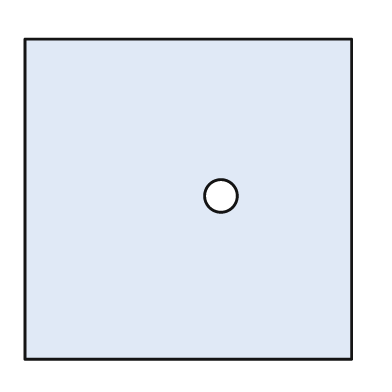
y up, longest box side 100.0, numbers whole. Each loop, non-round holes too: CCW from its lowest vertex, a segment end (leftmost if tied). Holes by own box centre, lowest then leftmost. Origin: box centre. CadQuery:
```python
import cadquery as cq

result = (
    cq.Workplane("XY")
    .moveTo(-50.0, -49.0)
    .lineTo(50.0, -49.0)
    .lineTo(50.0, 49.0)
    .lineTo(-50.0, 49.0)
    .close()
    .moveTo(10.0, 1.0)
    .circle(5.0)
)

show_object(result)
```